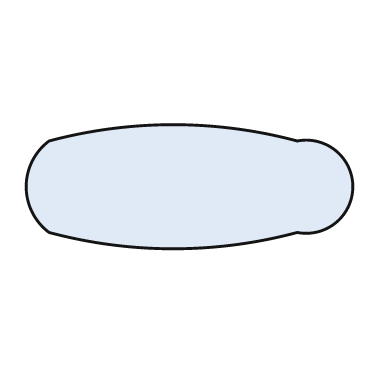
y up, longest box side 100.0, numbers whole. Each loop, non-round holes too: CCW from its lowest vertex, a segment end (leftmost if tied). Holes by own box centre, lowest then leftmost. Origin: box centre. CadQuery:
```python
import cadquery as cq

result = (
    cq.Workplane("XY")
    .moveTo(-43.0, -14.0)
    .threePointArc((-5.0, -19.0), (33.0, -14.0))
    .threePointArc((50.0, 0.0), (33.0, 14.0))
    .threePointArc((-5.0, 19.0), (-43.0, 14.0))
    .threePointArc((-50.0, 0.0), (-43.0, -14.0))
    .close()
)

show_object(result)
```